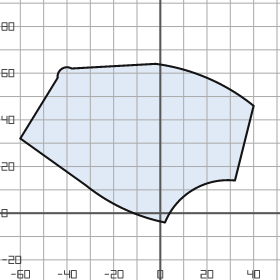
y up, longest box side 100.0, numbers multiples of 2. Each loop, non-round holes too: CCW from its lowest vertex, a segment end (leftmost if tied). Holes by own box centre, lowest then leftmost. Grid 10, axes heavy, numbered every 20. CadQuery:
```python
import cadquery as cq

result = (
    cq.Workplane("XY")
    .moveTo(2.0, -4.0)
    .threePointArc((14.0, 10.0), (32.0, 14.0))
    .lineTo(40.0, 46.0)
    .threePointArc((20.0, 58.0), (-2.0, 64.0))
    .lineTo(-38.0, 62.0)
    .threePointArc((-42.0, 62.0), (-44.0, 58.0))
    .lineTo(-60.0, 32.0)
    .lineTo(-32.0, 12.0)
    .threePointArc((-16.0, 2.0), (2.0, -4.0))
    .close()
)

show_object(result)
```